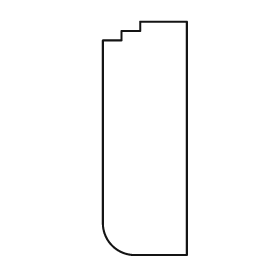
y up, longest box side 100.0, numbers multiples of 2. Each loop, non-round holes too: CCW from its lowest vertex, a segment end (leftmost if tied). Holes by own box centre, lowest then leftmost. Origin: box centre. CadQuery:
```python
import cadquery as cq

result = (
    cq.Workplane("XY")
    .moveTo(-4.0, -50.0)
    .lineTo(18.0, -50.0)
    .lineTo(18.0, 50.0)
    .lineTo(-2.0, 50.0)
    .lineTo(-2.0, 46.0)
    .lineTo(-10.0, 46.0)
    .lineTo(-10.0, 42.0)
    .lineTo(-18.0, 42.0)
    .lineTo(-18.0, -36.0)
    .threePointArc((-14.0, -46.0), (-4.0, -50.0))
    .close()
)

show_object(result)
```